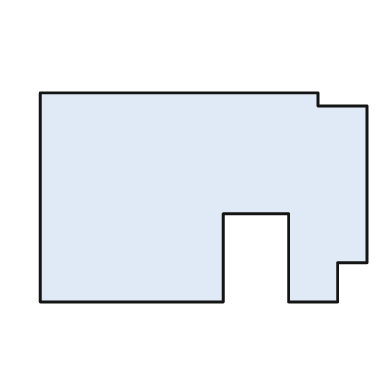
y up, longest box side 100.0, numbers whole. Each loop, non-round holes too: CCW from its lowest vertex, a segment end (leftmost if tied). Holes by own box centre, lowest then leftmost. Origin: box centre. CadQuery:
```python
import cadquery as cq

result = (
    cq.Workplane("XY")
    .moveTo(-50.0, -32.0)
    .lineTo(6.0, -32.0)
    .lineTo(6.0, -5.0)
    .lineTo(26.0, -5.0)
    .lineTo(26.0, -32.0)
    .lineTo(41.0, -32.0)
    .lineTo(41.0, -20.0)
    .lineTo(50.0, -20.0)
    .lineTo(50.0, 28.0)
    .lineTo(35.0, 28.0)
    .lineTo(35.0, 32.0)
    .lineTo(-50.0, 32.0)
    .close()
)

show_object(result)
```